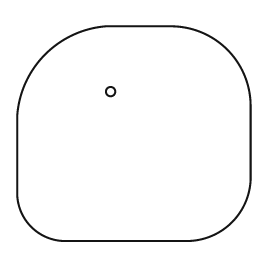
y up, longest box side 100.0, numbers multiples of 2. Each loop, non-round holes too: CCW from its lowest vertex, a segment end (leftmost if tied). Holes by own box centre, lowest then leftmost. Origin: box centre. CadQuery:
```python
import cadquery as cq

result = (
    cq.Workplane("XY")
    .moveTo(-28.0, -46.0)
    .lineTo(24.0, -46.0)
    .threePointArc((42.0, -38.0), (50.0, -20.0))
    .lineTo(50.0, 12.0)
    .threePointArc((40.0, 36.0), (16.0, 46.0))
    .lineTo(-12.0, 46.0)
    .threePointArc((-38.0, 34.0), (-50.0, 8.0))
    .lineTo(-50.0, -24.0)
    .threePointArc((-44.0, -40.0), (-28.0, -46.0))
    .close()
    .moveTo(-10.0, 18.0)
    .circle(2.0)
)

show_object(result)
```